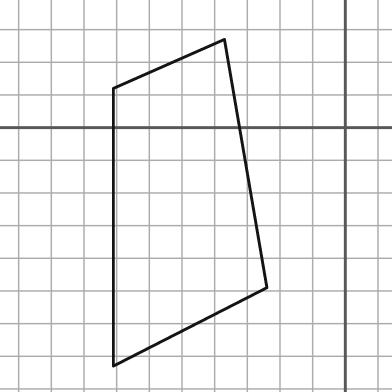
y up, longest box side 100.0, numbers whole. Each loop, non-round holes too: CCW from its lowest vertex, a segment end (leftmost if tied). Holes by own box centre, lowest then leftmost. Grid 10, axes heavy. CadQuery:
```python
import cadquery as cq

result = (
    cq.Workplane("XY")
    .moveTo(-71.0, -73.0)
    .lineTo(-24.0, -49.0)
    .lineTo(-37.0, 27.0)
    .lineTo(-71.0, 12.0)
    .close()
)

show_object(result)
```